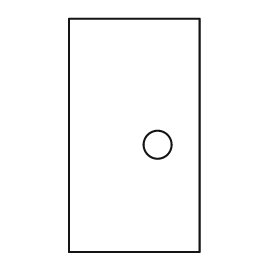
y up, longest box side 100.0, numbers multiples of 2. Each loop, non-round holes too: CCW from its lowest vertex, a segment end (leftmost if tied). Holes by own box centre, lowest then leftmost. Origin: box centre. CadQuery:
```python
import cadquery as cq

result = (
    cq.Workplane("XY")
    .moveTo(-28.0, -50.0)
    .lineTo(28.0, -50.0)
    .lineTo(28.0, 50.0)
    .lineTo(-28.0, 50.0)
    .close()
    .moveTo(10.0, -4.0)
    .circle(6.0)
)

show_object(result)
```